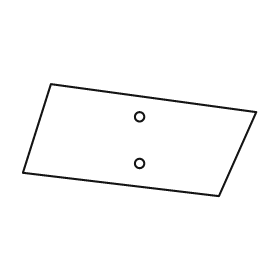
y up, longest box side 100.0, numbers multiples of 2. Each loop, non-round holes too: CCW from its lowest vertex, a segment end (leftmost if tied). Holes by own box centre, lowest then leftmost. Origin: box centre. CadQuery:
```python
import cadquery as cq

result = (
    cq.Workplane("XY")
    .moveTo(34.0, -24.0)
    .lineTo(50.0, 12.0)
    .lineTo(-38.0, 24.0)
    .lineTo(-50.0, -14.0)
    .close()
    .moveTo(0.0, -10.0)
    .circle(2.0)
    .moveTo(0.0, 10.0)
    .circle(2.0)
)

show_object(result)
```